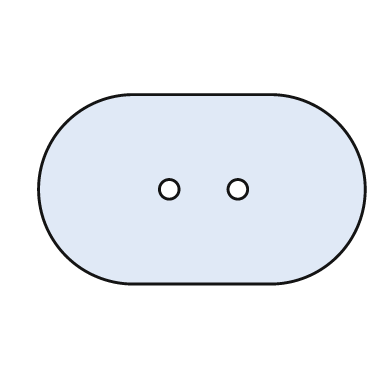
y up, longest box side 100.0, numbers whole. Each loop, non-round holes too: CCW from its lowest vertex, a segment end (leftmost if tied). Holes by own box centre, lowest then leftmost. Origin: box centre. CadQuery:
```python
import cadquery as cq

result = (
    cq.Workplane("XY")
    .moveTo(-21.0, -29.0)
    .lineTo(21.0, -29.0)
    .threePointArc((50.0, 0.0), (21.0, 29.0))
    .lineTo(-21.0, 29.0)
    .threePointArc((-50.0, 0.0), (-21.0, -29.0))
    .close()
    .moveTo(-10.0, 0.0)
    .circle(3.0)
    .moveTo(11.0, 0.0)
    .circle(3.0)
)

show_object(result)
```